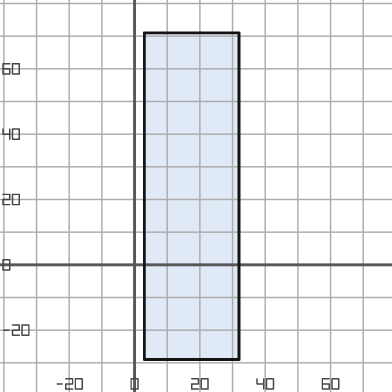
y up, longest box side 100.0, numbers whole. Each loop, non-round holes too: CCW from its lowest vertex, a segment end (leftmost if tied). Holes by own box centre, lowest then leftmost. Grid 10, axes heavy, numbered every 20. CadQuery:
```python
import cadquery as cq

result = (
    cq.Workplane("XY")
    .moveTo(3.0, -29.0)
    .lineTo(32.0, -29.0)
    .lineTo(32.0, 71.0)
    .lineTo(3.0, 71.0)
    .close()
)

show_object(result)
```